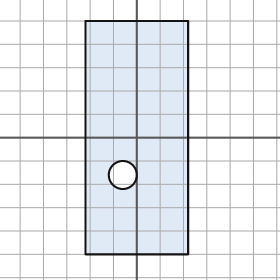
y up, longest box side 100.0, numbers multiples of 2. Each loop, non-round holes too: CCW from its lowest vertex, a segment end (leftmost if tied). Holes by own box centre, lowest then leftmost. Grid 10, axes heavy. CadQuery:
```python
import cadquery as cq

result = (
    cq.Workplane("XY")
    .moveTo(-22.0, -50.0)
    .lineTo(22.0, -50.0)
    .lineTo(22.0, 50.0)
    .lineTo(-22.0, 50.0)
    .close()
    .moveTo(-6.0, -16.0)
    .circle(6.0)
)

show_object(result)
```